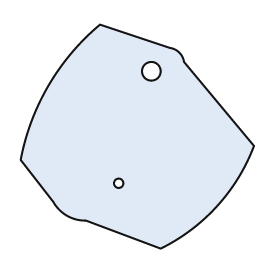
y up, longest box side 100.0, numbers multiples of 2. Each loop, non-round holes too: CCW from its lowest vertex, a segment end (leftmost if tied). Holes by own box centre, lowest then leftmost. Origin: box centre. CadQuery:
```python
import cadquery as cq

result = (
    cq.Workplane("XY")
    .moveTo(10.0, -48.0)
    .threePointArc((34.0, -30.0), (50.0, -4.0))
    .lineTo(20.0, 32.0)
    .threePointArc((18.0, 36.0), (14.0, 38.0))
    .lineTo(-16.0, 48.0)
    .threePointArc((-38.0, 22.0), (-50.0, -10.0))
    .lineTo(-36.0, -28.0)
    .threePointArc((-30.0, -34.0), (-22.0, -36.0))
    .close()
    .moveTo(-8.0, -20.0)
    .circle(2.0)
    .moveTo(6.0, 28.0)
    .circle(4.0)
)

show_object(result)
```